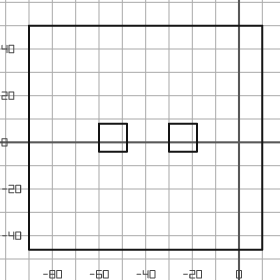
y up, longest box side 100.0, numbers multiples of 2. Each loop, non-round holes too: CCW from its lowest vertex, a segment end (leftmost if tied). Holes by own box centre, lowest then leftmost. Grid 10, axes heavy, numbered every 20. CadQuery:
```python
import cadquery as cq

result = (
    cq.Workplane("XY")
    .moveTo(-90.0, -46.0)
    .lineTo(10.0, -46.0)
    .lineTo(10.0, 50.0)
    .lineTo(-90.0, 50.0)
    .close()
    .moveTo(-60.0, -4.0)
    .lineTo(-48.0, -4.0)
    .lineTo(-48.0, 8.0)
    .lineTo(-60.0, 8.0)
    .close()
    .moveTo(-30.0, -4.0)
    .lineTo(-18.0, -4.0)
    .lineTo(-18.0, 8.0)
    .lineTo(-30.0, 8.0)
    .close()
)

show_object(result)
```